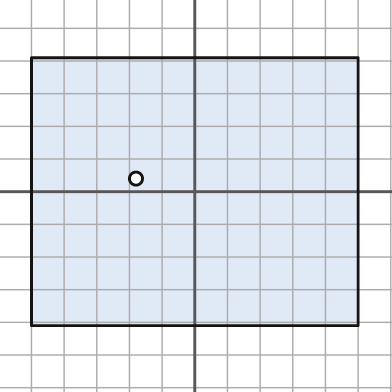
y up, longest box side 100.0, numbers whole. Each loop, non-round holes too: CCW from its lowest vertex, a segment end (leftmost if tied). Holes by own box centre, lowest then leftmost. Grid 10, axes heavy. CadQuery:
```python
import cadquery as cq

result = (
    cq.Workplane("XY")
    .moveTo(-50.0, -41.0)
    .lineTo(50.0, -41.0)
    .lineTo(50.0, 41.0)
    .lineTo(-50.0, 41.0)
    .close()
    .moveTo(-18.0, 4.0)
    .circle(2.0)
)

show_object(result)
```